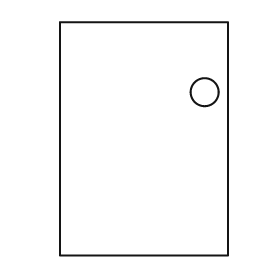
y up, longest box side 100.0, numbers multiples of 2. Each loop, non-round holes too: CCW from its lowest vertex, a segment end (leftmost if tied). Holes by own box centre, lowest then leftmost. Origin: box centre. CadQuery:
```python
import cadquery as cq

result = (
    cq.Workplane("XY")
    .moveTo(-36.0, -50.0)
    .lineTo(36.0, -50.0)
    .lineTo(36.0, 50.0)
    .lineTo(-36.0, 50.0)
    .close()
    .moveTo(26.0, 20.0)
    .circle(6.0)
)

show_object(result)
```